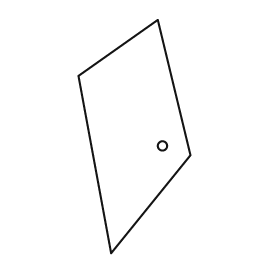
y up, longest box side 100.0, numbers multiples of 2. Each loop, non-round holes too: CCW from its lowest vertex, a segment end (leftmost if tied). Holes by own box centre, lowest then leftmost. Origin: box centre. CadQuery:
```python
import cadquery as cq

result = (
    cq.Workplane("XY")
    .moveTo(-10.0, -50.0)
    .lineTo(24.0, -8.0)
    .lineTo(10.0, 50.0)
    .lineTo(-24.0, 26.0)
    .close()
    .moveTo(12.0, -4.0)
    .circle(2.0)
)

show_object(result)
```